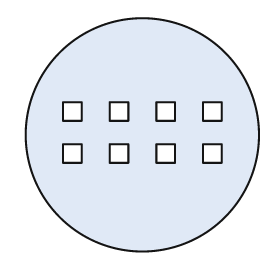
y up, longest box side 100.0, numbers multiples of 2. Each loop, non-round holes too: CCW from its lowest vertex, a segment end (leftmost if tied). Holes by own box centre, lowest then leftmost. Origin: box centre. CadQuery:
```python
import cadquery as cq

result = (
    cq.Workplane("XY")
    .moveTo(0.0, 0.0)
    .circle(50.0)
    .moveTo(-34.0, -12.0)
    .lineTo(-26.0, -12.0)
    .lineTo(-26.0, -4.0)
    .lineTo(-34.0, -4.0)
    .close()
    .moveTo(-14.0, -12.0)
    .lineTo(-6.0, -12.0)
    .lineTo(-6.0, -4.0)
    .lineTo(-14.0, -4.0)
    .close()
    .moveTo(6.0, -12.0)
    .lineTo(14.0, -12.0)
    .lineTo(14.0, -4.0)
    .lineTo(6.0, -4.0)
    .close()
    .moveTo(26.0, -12.0)
    .lineTo(34.0, -12.0)
    .lineTo(34.0, -4.0)
    .lineTo(26.0, -4.0)
    .close()
    .moveTo(-34.0, 6.0)
    .lineTo(-26.0, 6.0)
    .lineTo(-26.0, 14.0)
    .lineTo(-34.0, 14.0)
    .close()
    .moveTo(-14.0, 6.0)
    .lineTo(-6.0, 6.0)
    .lineTo(-6.0, 14.0)
    .lineTo(-14.0, 14.0)
    .close()
    .moveTo(6.0, 6.0)
    .lineTo(14.0, 6.0)
    .lineTo(14.0, 14.0)
    .lineTo(6.0, 14.0)
    .close()
    .moveTo(26.0, 6.0)
    .lineTo(34.0, 6.0)
    .lineTo(34.0, 14.0)
    .lineTo(26.0, 14.0)
    .close()
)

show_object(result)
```